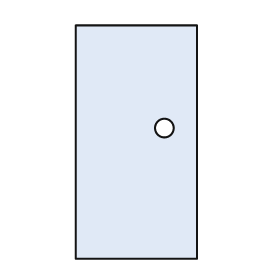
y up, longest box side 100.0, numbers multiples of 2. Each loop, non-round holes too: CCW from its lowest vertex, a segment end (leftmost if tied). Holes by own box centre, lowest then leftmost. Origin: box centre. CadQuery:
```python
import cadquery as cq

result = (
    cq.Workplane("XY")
    .moveTo(-26.0, -50.0)
    .lineTo(26.0, -50.0)
    .lineTo(26.0, 50.0)
    .lineTo(-26.0, 50.0)
    .close()
    .moveTo(12.0, 6.0)
    .circle(4.0)
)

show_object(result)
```